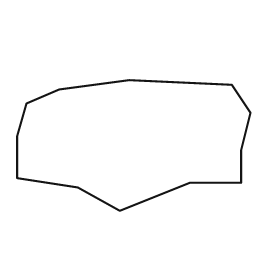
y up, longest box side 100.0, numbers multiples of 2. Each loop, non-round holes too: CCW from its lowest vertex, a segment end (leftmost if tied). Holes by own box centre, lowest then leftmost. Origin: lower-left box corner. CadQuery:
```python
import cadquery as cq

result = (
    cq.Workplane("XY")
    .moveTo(44.0, 0.0)
    .lineTo(74.0, 12.0)
    .lineTo(96.0, 12.0)
    .lineTo(96.0, 26.0)
    .lineTo(100.0, 42.0)
    .lineTo(92.0, 54.0)
    .lineTo(48.0, 56.0)
    .lineTo(18.0, 52.0)
    .lineTo(4.0, 46.0)
    .lineTo(0.0, 32.0)
    .lineTo(0.0, 14.0)
    .lineTo(26.0, 10.0)
    .close()
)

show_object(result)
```